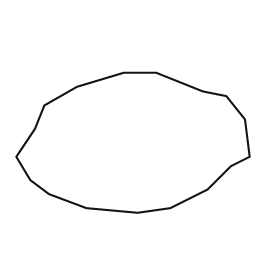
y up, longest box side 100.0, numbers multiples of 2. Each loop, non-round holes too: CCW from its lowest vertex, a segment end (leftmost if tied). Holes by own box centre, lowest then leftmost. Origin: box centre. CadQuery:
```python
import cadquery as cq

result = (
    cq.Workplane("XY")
    .moveTo(2.0, -30.0)
    .lineTo(16.0, -28.0)
    .lineTo(32.0, -20.0)
    .lineTo(42.0, -10.0)
    .lineTo(50.0, -6.0)
    .lineTo(48.0, 10.0)
    .lineTo(40.0, 20.0)
    .lineTo(30.0, 22.0)
    .lineTo(10.0, 30.0)
    .lineTo(-4.0, 30.0)
    .lineTo(-24.0, 24.0)
    .lineTo(-38.0, 16.0)
    .lineTo(-42.0, 6.0)
    .lineTo(-50.0, -6.0)
    .lineTo(-44.0, -16.0)
    .lineTo(-36.0, -22.0)
    .lineTo(-20.0, -28.0)
    .close()
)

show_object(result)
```